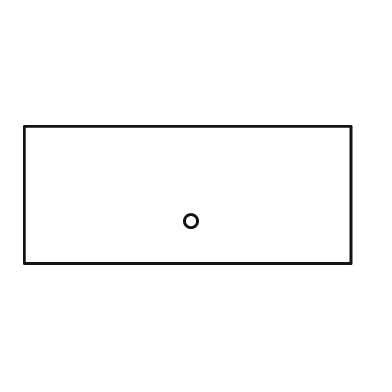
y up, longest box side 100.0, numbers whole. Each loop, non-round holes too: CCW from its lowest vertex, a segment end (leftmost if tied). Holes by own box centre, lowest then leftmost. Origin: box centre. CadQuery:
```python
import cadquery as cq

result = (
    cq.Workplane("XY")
    .moveTo(-50.0, -21.0)
    .lineTo(50.0, -21.0)
    .lineTo(50.0, 21.0)
    .lineTo(-50.0, 21.0)
    .close()
    .moveTo(1.0, -8.0)
    .circle(2.0)
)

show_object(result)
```